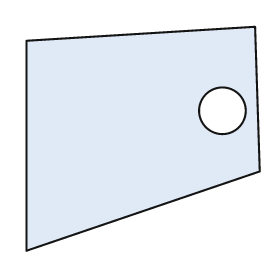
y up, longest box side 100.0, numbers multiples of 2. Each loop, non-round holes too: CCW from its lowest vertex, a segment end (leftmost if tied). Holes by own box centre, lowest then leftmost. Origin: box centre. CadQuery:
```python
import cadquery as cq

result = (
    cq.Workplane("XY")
    .moveTo(-50.0, -48.0)
    .lineTo(50.0, -14.0)
    .lineTo(48.0, 48.0)
    .lineTo(-50.0, 42.0)
    .close()
    .moveTo(34.0, 12.0)
    .circle(10.0)
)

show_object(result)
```